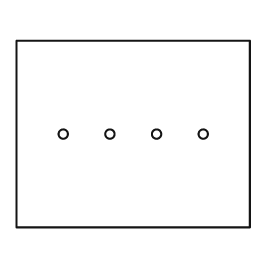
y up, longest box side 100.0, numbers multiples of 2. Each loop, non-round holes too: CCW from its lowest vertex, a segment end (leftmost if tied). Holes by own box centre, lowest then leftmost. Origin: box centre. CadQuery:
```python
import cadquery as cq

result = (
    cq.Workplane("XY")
    .moveTo(-50.0, -40.0)
    .lineTo(50.0, -40.0)
    .lineTo(50.0, 40.0)
    .lineTo(-50.0, 40.0)
    .close()
    .moveTo(-30.0, 0.0)
    .circle(2.0)
    .moveTo(-10.0, 0.0)
    .circle(2.0)
    .moveTo(10.0, 0.0)
    .circle(2.0)
    .moveTo(30.0, 0.0)
    .circle(2.0)
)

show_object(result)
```